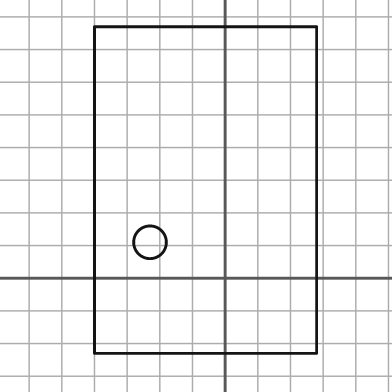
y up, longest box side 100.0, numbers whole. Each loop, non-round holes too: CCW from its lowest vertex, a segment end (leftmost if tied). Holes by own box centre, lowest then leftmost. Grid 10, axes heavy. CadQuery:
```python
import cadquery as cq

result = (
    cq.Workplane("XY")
    .moveTo(-40.0, -23.0)
    .lineTo(28.0, -23.0)
    .lineTo(28.0, 77.0)
    .lineTo(-40.0, 77.0)
    .close()
    .moveTo(-23.0, 11.0)
    .circle(5.0)
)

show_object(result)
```